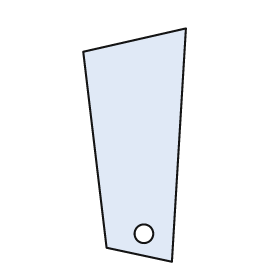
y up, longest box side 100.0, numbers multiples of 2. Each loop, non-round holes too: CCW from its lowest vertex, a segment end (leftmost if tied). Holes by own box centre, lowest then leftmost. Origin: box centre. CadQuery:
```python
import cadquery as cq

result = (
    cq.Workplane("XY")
    .moveTo(16.0, -50.0)
    .lineTo(22.0, 50.0)
    .lineTo(-22.0, 40.0)
    .lineTo(-12.0, -44.0)
    .close()
    .moveTo(4.0, -38.0)
    .circle(4.0)
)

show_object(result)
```